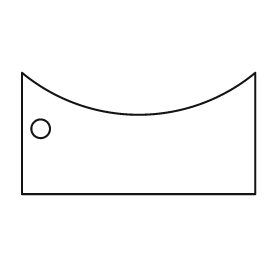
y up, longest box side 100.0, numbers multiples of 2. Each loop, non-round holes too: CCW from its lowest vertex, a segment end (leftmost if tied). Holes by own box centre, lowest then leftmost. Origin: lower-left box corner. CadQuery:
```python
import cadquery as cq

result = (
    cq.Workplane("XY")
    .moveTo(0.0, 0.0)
    .lineTo(100.0, 0.0)
    .lineTo(100.0, 52.0)
    .threePointArc((50.0, 34.0), (0.0, 52.0))
    .close()
    .moveTo(8.0, 28.0)
    .circle(4.0)
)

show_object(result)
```